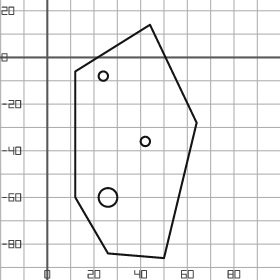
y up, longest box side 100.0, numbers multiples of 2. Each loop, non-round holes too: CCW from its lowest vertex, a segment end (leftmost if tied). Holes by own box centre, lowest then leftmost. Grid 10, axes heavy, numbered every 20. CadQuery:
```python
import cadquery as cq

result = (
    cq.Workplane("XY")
    .moveTo(50.0, -86.0)
    .lineTo(64.0, -28.0)
    .lineTo(44.0, 14.0)
    .lineTo(12.0, -6.0)
    .lineTo(12.0, -60.0)
    .lineTo(26.0, -84.0)
    .close()
    .moveTo(26.0, -60.0)
    .circle(4.0)
    .moveTo(42.0, -36.0)
    .circle(2.0)
    .moveTo(24.0, -8.0)
    .circle(2.0)
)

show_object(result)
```